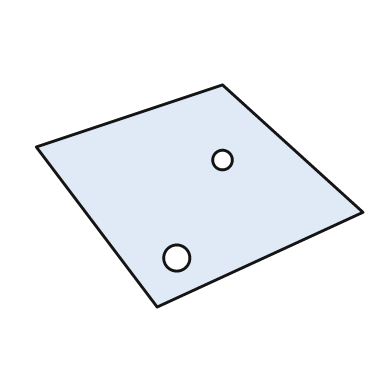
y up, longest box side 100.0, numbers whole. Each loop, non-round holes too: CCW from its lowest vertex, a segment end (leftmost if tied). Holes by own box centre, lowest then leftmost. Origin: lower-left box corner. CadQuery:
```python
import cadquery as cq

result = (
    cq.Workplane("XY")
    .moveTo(37.0, 0.0)
    .lineTo(100.0, 29.0)
    .lineTo(57.0, 68.0)
    .lineTo(0.0, 49.0)
    .close()
    .moveTo(43.0, 15.0)
    .circle(4.0)
    .moveTo(57.0, 45.0)
    .circle(3.0)
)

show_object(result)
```